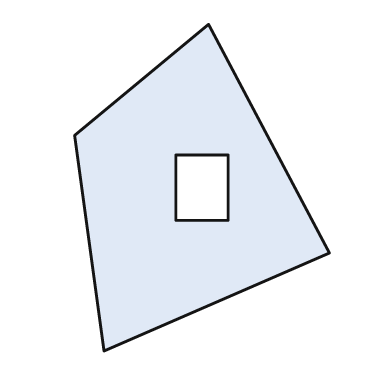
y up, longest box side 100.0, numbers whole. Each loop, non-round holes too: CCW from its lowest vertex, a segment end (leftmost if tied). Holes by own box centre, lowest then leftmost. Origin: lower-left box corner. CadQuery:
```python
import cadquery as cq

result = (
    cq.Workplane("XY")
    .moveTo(9.0, 0.0)
    .lineTo(78.0, 30.0)
    .lineTo(41.0, 100.0)
    .lineTo(0.0, 66.0)
    .close()
    .moveTo(31.0, 40.0)
    .lineTo(47.0, 40.0)
    .lineTo(47.0, 60.0)
    .lineTo(31.0, 60.0)
    .close()
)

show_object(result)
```